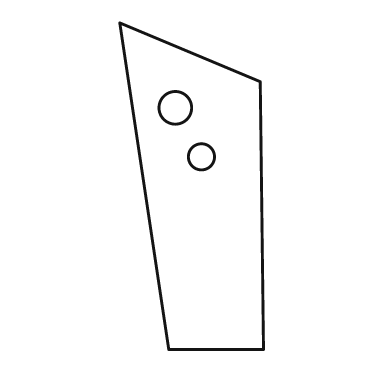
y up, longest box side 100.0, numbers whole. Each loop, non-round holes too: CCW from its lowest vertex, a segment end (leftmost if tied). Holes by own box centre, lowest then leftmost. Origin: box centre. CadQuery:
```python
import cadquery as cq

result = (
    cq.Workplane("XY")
    .moveTo(-7.0, -50.0)
    .lineTo(22.0, -50.0)
    .lineTo(21.0, 32.0)
    .lineTo(-22.0, 50.0)
    .close()
    .moveTo(3.0, 9.0)
    .circle(4.0)
    .moveTo(-5.0, 24.0)
    .circle(5.0)
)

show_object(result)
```